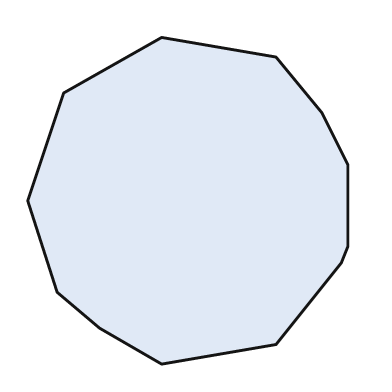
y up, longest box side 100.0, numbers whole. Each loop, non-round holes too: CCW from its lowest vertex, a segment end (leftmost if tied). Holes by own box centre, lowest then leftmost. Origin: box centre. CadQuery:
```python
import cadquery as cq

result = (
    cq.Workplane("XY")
    .moveTo(-8.0, -50.0)
    .lineTo(27.0, -44.0)
    .lineTo(47.0, -19.0)
    .lineTo(49.0, -14.0)
    .lineTo(49.0, 11.0)
    .lineTo(41.0, 27.0)
    .lineTo(27.0, 44.0)
    .lineTo(-8.0, 50.0)
    .lineTo(-38.0, 33.0)
    .lineTo(-49.0, 0.0)
    .lineTo(-40.0, -28.0)
    .lineTo(-27.0, -39.0)
    .close()
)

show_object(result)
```